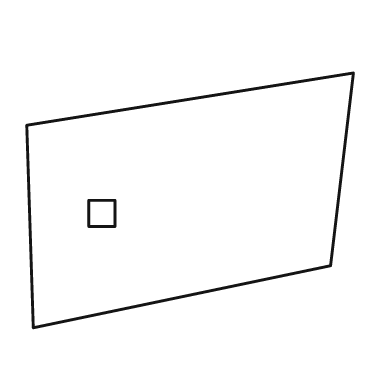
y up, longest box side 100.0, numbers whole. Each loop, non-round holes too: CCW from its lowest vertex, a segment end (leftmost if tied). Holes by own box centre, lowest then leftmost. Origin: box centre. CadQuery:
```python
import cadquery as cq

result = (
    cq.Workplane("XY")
    .moveTo(-48.0, -39.0)
    .lineTo(43.0, -20.0)
    .lineTo(50.0, 39.0)
    .lineTo(-50.0, 23.0)
    .close()
    .moveTo(-31.0, -8.0)
    .lineTo(-23.0, -8.0)
    .lineTo(-23.0, 0.0)
    .lineTo(-31.0, 0.0)
    .close()
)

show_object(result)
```